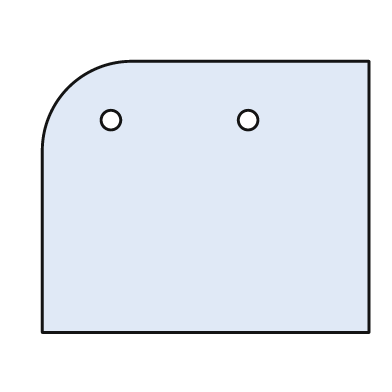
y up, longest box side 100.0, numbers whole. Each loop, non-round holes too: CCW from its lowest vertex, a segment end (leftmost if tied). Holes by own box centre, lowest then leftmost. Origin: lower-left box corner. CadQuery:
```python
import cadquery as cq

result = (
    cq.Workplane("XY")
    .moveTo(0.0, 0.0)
    .lineTo(100.0, 0.0)
    .lineTo(100.0, 83.0)
    .lineTo(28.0, 83.0)
    .threePointArc((8.0, 75.0), (0.0, 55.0))
    .close()
    .moveTo(21.0, 65.0)
    .circle(3.0)
    .moveTo(63.0, 65.0)
    .circle(3.0)
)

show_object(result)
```